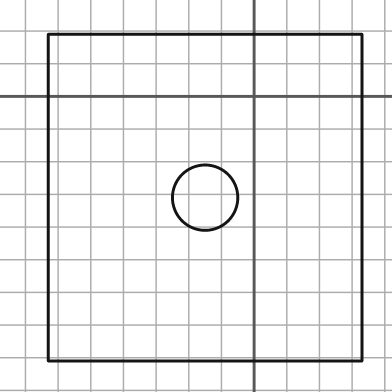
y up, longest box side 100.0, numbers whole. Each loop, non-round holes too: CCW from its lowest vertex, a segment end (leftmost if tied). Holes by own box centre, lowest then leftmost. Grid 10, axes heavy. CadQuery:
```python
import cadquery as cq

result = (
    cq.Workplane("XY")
    .moveTo(-63.0, -81.0)
    .lineTo(33.0, -81.0)
    .lineTo(33.0, 19.0)
    .lineTo(-63.0, 19.0)
    .close()
    .moveTo(-15.0, -31.0)
    .circle(10.0)
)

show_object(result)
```